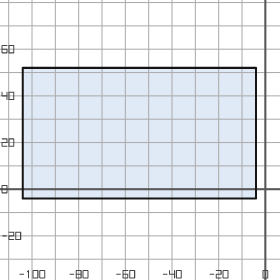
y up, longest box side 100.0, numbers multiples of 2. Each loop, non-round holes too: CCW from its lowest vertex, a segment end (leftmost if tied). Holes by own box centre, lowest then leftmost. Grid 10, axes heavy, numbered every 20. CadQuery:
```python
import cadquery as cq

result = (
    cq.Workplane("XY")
    .moveTo(-104.0, -4.0)
    .lineTo(-4.0, -4.0)
    .lineTo(-4.0, 52.0)
    .lineTo(-104.0, 52.0)
    .close()
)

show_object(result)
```